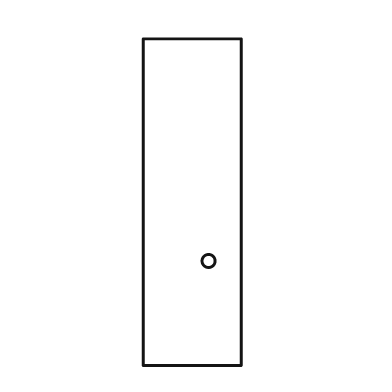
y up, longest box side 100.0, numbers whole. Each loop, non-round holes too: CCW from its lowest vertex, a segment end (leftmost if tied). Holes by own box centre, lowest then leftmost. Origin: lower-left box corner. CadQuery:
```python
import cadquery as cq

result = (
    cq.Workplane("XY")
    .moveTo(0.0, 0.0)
    .lineTo(30.0, 0.0)
    .lineTo(30.0, 100.0)
    .lineTo(0.0, 100.0)
    .close()
    .moveTo(20.0, 32.0)
    .circle(2.0)
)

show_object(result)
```